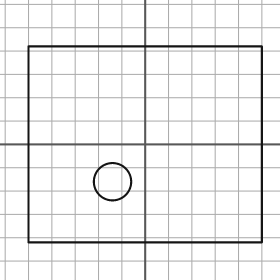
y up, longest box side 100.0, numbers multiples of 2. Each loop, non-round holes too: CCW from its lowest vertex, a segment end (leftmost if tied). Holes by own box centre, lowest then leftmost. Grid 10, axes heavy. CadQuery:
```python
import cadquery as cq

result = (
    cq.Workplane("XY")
    .moveTo(-50.0, -42.0)
    .lineTo(50.0, -42.0)
    .lineTo(50.0, 42.0)
    .lineTo(-50.0, 42.0)
    .close()
    .moveTo(-14.0, -16.0)
    .circle(8.0)
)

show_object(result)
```